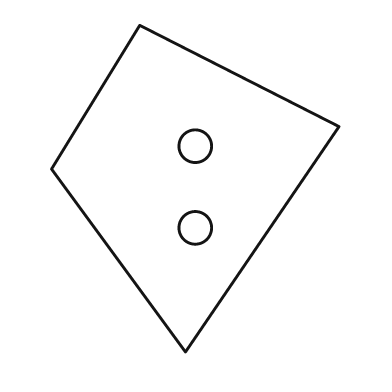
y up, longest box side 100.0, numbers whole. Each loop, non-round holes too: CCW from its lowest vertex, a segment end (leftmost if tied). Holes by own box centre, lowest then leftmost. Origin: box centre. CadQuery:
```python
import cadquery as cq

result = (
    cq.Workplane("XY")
    .moveTo(-3.0, -50.0)
    .lineTo(44.0, 19.0)
    .lineTo(-17.0, 50.0)
    .lineTo(-44.0, 6.0)
    .close()
    .moveTo(0.0, -12.0)
    .circle(5.0)
    .moveTo(0.0, 13.0)
    .circle(5.0)
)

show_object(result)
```